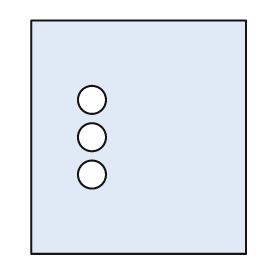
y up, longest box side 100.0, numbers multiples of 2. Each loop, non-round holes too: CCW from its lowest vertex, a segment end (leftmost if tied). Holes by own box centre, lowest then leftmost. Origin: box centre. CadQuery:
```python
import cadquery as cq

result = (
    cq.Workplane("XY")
    .moveTo(-46.0, -50.0)
    .lineTo(46.0, -50.0)
    .lineTo(46.0, 50.0)
    .lineTo(-46.0, 50.0)
    .close()
    .moveTo(-20.0, -16.0)
    .circle(6.0)
    .moveTo(-20.0, 0.0)
    .circle(6.0)
    .moveTo(-20.0, 16.0)
    .circle(6.0)
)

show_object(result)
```